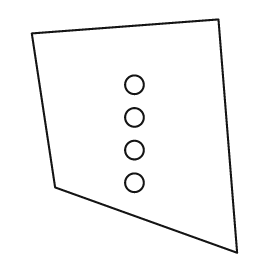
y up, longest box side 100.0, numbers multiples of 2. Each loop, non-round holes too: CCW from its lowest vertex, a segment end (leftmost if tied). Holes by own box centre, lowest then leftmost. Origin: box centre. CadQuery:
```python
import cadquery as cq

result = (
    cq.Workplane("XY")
    .moveTo(44.0, -50.0)
    .lineTo(36.0, 50.0)
    .lineTo(-44.0, 44.0)
    .lineTo(-34.0, -22.0)
    .close()
    .moveTo(0.0, -20.0)
    .circle(4.0)
    .moveTo(0.0, -6.0)
    .circle(4.0)
    .moveTo(0.0, 8.0)
    .circle(4.0)
    .moveTo(0.0, 22.0)
    .circle(4.0)
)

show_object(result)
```